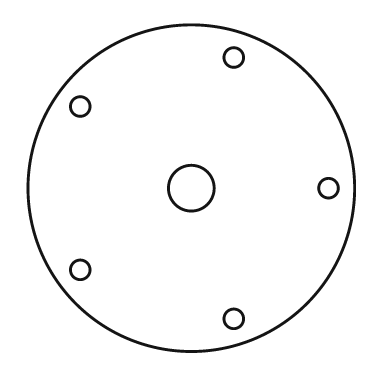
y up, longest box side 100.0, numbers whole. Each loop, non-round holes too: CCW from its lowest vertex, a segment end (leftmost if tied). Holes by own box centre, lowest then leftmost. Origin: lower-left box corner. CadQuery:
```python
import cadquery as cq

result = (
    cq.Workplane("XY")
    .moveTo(50.0, 50.0)
    .circle(50.0)
    .moveTo(63.0, 10.0)
    .circle(3.0)
    .moveTo(16.0, 25.0)
    .circle(3.0)
    .moveTo(50.0, 50.0)
    .circle(7.0)
    .moveTo(92.0, 50.0)
    .circle(3.0)
    .moveTo(16.0, 75.0)
    .circle(3.0)
    .moveTo(63.0, 90.0)
    .circle(3.0)
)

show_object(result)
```